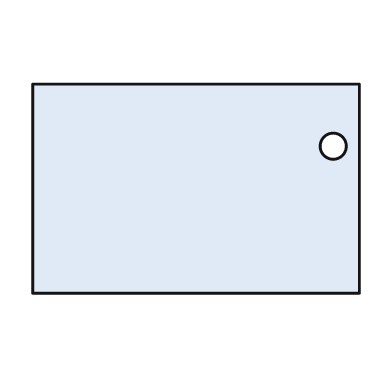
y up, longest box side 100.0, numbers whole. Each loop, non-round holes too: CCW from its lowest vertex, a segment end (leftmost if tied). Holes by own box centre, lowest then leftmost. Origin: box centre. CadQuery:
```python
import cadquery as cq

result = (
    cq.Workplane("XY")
    .moveTo(-50.0, -32.0)
    .lineTo(50.0, -32.0)
    .lineTo(50.0, 32.0)
    .lineTo(-50.0, 32.0)
    .close()
    .moveTo(42.0, 13.0)
    .circle(4.0)
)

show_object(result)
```